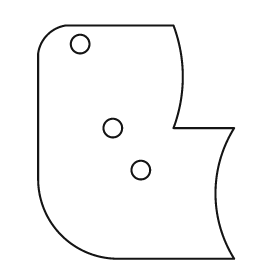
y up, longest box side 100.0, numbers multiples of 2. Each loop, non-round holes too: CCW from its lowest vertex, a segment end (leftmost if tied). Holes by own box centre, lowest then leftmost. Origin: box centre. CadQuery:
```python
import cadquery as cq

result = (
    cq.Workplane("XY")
    .moveTo(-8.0, -50.0)
    .lineTo(42.0, -50.0)
    .threePointArc((34.0, -22.0), (42.0, 6.0))
    .lineTo(16.0, 6.0)
    .threePointArc((20.0, 28.0), (16.0, 50.0))
    .lineTo(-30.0, 50.0)
    .threePointArc((-38.0, 46.0), (-42.0, 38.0))
    .lineTo(-42.0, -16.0)
    .threePointArc((-32.0, -40.0), (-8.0, -50.0))
    .close()
    .moveTo(2.0, -12.0)
    .circle(4.0)
    .moveTo(-10.0, 6.0)
    .circle(4.0)
    .moveTo(-24.0, 42.0)
    .circle(4.0)
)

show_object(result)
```